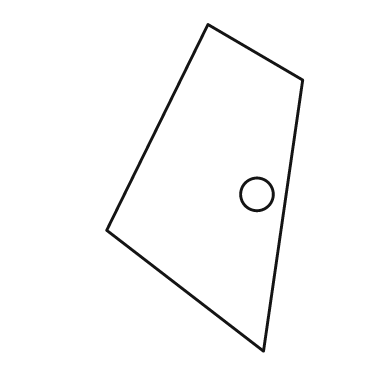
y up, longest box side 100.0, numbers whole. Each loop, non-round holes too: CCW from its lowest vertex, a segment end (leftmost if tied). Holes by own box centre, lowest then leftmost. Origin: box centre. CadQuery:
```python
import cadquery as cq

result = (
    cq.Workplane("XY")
    .moveTo(18.0, -50.0)
    .lineTo(30.0, 33.0)
    .lineTo(1.0, 50.0)
    .lineTo(-30.0, -13.0)
    .close()
    .moveTo(16.0, -2.0)
    .circle(5.0)
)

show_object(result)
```